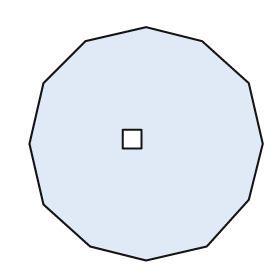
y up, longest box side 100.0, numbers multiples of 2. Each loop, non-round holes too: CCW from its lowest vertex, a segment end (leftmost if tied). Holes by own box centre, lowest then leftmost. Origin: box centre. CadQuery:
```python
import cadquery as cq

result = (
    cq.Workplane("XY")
    .moveTo(0.0, -50.0)
    .lineTo(26.0, -44.0)
    .lineTo(44.0, -24.0)
    .lineTo(50.0, 0.0)
    .lineTo(44.0, 26.0)
    .lineTo(24.0, 44.0)
    .lineTo(0.0, 50.0)
    .lineTo(-26.0, 44.0)
    .lineTo(-44.0, 26.0)
    .lineTo(-50.0, 0.0)
    .lineTo(-44.0, -26.0)
    .lineTo(-24.0, -44.0)
    .close()
    .moveTo(-10.0, -2.0)
    .lineTo(-2.0, -2.0)
    .lineTo(-2.0, 6.0)
    .lineTo(-10.0, 6.0)
    .close()
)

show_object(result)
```